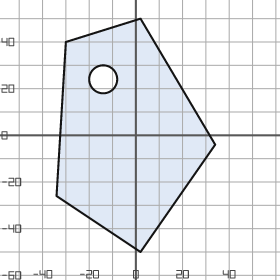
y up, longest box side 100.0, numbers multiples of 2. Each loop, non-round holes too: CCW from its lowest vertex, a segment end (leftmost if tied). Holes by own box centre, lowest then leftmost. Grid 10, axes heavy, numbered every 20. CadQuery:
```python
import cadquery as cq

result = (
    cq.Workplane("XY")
    .moveTo(2.0, -50.0)
    .lineTo(34.0, -4.0)
    .lineTo(2.0, 50.0)
    .lineTo(-30.0, 40.0)
    .lineTo(-34.0, -26.0)
    .close()
    .moveTo(-14.0, 24.0)
    .circle(6.0)
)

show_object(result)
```